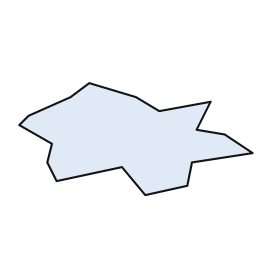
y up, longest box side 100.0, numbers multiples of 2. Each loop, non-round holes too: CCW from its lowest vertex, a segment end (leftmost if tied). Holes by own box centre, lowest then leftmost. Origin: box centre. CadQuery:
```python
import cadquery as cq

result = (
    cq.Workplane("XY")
    .moveTo(4.0, -24.0)
    .lineTo(22.0, -20.0)
    .lineTo(24.0, -10.0)
    .lineTo(50.0, -6.0)
    .lineTo(38.0, 2.0)
    .lineTo(26.0, 4.0)
    .lineTo(32.0, 16.0)
    .lineTo(10.0, 12.0)
    .lineTo(0.0, 18.0)
    .lineTo(-20.0, 24.0)
    .lineTo(-28.0, 18.0)
    .lineTo(-46.0, 10.0)
    .lineTo(-50.0, 6.0)
    .lineTo(-36.0, -2.0)
    .lineTo(-38.0, -10.0)
    .lineTo(-34.0, -18.0)
    .lineTo(-6.0, -12.0)
    .close()
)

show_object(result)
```